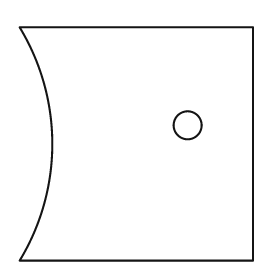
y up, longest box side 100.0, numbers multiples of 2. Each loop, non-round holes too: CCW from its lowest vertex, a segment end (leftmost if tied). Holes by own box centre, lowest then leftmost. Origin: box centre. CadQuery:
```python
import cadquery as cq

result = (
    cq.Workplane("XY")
    .moveTo(-50.0, -50.0)
    .lineTo(50.0, -50.0)
    .lineTo(50.0, 50.0)
    .lineTo(-50.0, 50.0)
    .threePointArc((-36.0, 0.0), (-50.0, -50.0))
    .close()
    .moveTo(22.0, 8.0)
    .circle(6.0)
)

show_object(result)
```